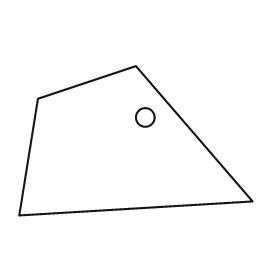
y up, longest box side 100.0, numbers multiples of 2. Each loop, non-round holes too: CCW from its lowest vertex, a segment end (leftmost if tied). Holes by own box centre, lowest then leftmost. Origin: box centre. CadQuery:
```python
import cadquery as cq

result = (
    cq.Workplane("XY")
    .moveTo(-50.0, -32.0)
    .lineTo(50.0, -26.0)
    .lineTo(0.0, 32.0)
    .lineTo(-42.0, 18.0)
    .close()
    .moveTo(4.0, 10.0)
    .circle(4.0)
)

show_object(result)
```